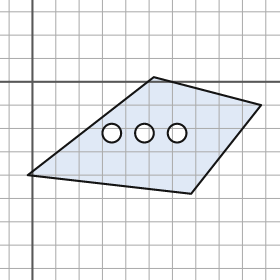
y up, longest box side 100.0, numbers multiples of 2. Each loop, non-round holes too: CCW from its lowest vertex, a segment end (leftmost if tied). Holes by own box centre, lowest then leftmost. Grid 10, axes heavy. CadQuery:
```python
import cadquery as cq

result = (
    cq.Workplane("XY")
    .moveTo(68.0, -48.0)
    .lineTo(98.0, -10.0)
    .lineTo(52.0, 2.0)
    .lineTo(-2.0, -40.0)
    .close()
    .moveTo(34.0, -22.0)
    .circle(4.0)
    .moveTo(48.0, -22.0)
    .circle(4.0)
    .moveTo(62.0, -22.0)
    .circle(4.0)
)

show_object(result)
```